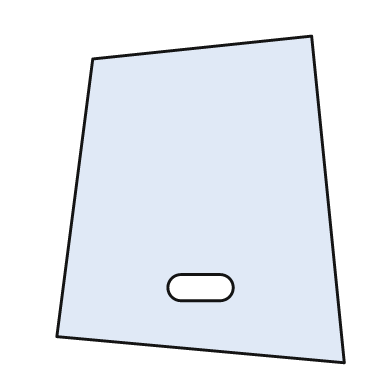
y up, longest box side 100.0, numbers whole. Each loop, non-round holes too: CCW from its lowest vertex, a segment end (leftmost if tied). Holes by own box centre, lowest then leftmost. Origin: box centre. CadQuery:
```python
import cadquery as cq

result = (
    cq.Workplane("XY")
    .moveTo(44.0, -50.0)
    .lineTo(34.0, 50.0)
    .lineTo(-33.0, 43.0)
    .lineTo(-44.0, -42.0)
    .close()
    .moveTo(-6.0, -31.0)
    .lineTo(6.0, -31.0)
    .threePointArc((10.0, -27.0), (6.0, -23.0))
    .lineTo(-6.0, -23.0)
    .threePointArc((-10.0, -27.0), (-6.0, -31.0))
    .close()
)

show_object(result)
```